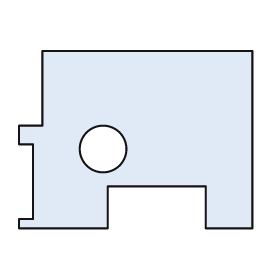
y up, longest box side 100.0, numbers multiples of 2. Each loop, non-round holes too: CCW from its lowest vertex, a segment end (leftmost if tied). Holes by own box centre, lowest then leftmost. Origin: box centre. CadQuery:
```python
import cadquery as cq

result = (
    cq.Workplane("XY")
    .moveTo(-50.0, -38.0)
    .lineTo(-12.0, -38.0)
    .lineTo(-12.0, -20.0)
    .lineTo(30.0, -20.0)
    .lineTo(30.0, -38.0)
    .lineTo(50.0, -38.0)
    .lineTo(50.0, 38.0)
    .lineTo(-40.0, 38.0)
    .lineTo(-40.0, 6.0)
    .lineTo(-50.0, 6.0)
    .lineTo(-50.0, -2.0)
    .lineTo(-44.0, -2.0)
    .lineTo(-44.0, -34.0)
    .lineTo(-50.0, -34.0)
    .close()
    .moveTo(-14.0, -4.0)
    .circle(10.0)
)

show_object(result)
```